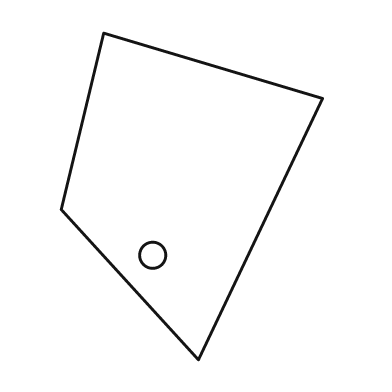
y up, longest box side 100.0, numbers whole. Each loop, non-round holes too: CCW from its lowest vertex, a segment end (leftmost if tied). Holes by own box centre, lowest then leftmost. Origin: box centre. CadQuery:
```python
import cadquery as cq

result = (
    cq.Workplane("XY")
    .moveTo(2.0, -50.0)
    .lineTo(40.0, 30.0)
    .lineTo(-27.0, 50.0)
    .lineTo(-40.0, -4.0)
    .close()
    .moveTo(-12.0, -18.0)
    .circle(4.0)
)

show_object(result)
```